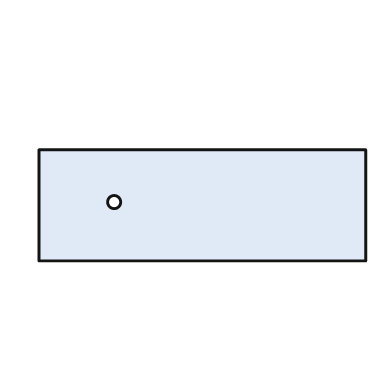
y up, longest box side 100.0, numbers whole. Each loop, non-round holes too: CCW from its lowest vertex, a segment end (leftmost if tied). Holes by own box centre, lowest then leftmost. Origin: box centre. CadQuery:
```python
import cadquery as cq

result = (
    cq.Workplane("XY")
    .moveTo(-50.0, -17.0)
    .lineTo(50.0, -17.0)
    .lineTo(50.0, 17.0)
    .lineTo(-50.0, 17.0)
    .close()
    .moveTo(-27.0, 1.0)
    .circle(2.0)
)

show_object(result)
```